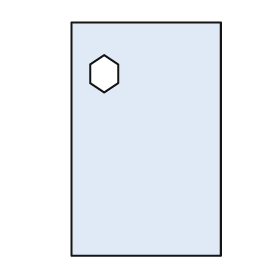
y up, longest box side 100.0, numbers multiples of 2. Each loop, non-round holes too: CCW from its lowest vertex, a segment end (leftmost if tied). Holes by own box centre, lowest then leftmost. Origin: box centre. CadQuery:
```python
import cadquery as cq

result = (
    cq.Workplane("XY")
    .moveTo(-32.0, -50.0)
    .lineTo(32.0, -50.0)
    .lineTo(32.0, 50.0)
    .lineTo(-32.0, 50.0)
    .close()
    .moveTo(-18.0, 20.0)
    .lineTo(-12.0, 24.0)
    .lineTo(-12.0, 32.0)
    .lineTo(-18.0, 36.0)
    .lineTo(-24.0, 32.0)
    .lineTo(-24.0, 24.0)
    .close()
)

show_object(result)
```